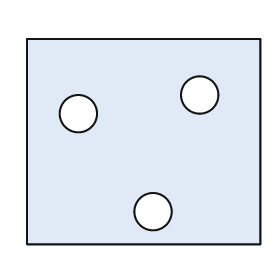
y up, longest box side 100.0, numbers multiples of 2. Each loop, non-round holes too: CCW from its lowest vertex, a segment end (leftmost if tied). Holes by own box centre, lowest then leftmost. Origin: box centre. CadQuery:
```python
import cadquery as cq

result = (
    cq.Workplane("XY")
    .moveTo(-50.0, -44.0)
    .lineTo(50.0, -44.0)
    .lineTo(50.0, 44.0)
    .lineTo(-50.0, 44.0)
    .close()
    .moveTo(4.0, -30.0)
    .circle(8.0)
    .moveTo(-28.0, 12.0)
    .circle(8.0)
    .moveTo(24.0, 20.0)
    .circle(8.0)
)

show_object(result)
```